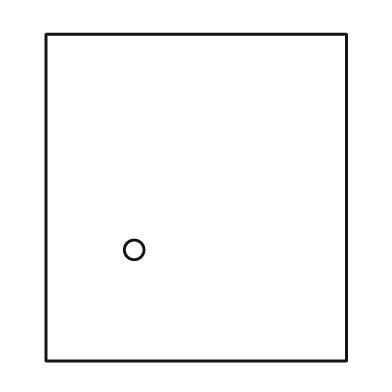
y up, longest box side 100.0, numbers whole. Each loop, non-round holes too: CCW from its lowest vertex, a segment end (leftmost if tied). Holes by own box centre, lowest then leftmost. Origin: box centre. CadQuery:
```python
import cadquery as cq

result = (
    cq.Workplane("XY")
    .moveTo(-46.0, -50.0)
    .lineTo(46.0, -50.0)
    .lineTo(46.0, 50.0)
    .lineTo(-46.0, 50.0)
    .close()
    .moveTo(-19.0, -16.0)
    .circle(3.0)
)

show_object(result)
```